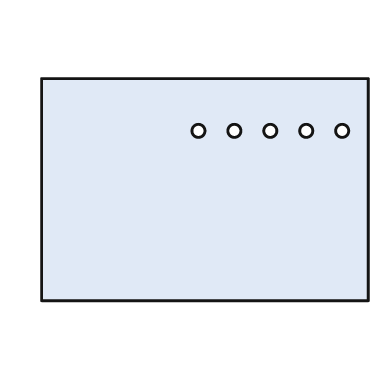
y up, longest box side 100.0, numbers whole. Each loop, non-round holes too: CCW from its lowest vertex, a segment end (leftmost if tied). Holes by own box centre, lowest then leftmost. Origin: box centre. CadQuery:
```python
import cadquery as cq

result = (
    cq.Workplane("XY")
    .moveTo(-50.0, -34.0)
    .lineTo(50.0, -34.0)
    .lineTo(50.0, 34.0)
    .lineTo(-50.0, 34.0)
    .close()
    .moveTo(-2.0, 18.0)
    .circle(2.0)
    .moveTo(9.0, 18.0)
    .circle(2.0)
    .moveTo(20.0, 18.0)
    .circle(2.0)
    .moveTo(31.0, 18.0)
    .circle(2.0)
    .moveTo(42.0, 18.0)
    .circle(2.0)
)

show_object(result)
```